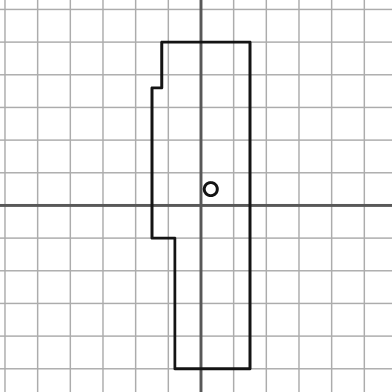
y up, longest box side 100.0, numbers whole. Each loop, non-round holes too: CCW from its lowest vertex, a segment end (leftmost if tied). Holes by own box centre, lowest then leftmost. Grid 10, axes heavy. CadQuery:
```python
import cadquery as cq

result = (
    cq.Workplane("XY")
    .moveTo(-8.0, -50.0)
    .lineTo(15.0, -50.0)
    .lineTo(15.0, 50.0)
    .lineTo(-12.0, 50.0)
    .lineTo(-12.0, 36.0)
    .lineTo(-15.0, 36.0)
    .lineTo(-15.0, -10.0)
    .lineTo(-8.0, -10.0)
    .close()
    .moveTo(3.0, 5.0)
    .circle(2.0)
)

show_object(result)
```